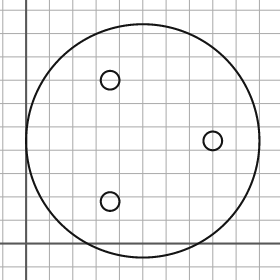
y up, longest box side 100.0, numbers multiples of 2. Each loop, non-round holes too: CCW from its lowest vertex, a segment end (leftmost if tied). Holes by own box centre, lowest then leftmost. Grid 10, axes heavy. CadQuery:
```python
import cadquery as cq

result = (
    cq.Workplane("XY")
    .moveTo(50.0, 44.0)
    .circle(50.0)
    .moveTo(36.0, 18.0)
    .circle(4.0)
    .moveTo(80.0, 44.0)
    .circle(4.0)
    .moveTo(36.0, 70.0)
    .circle(4.0)
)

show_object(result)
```